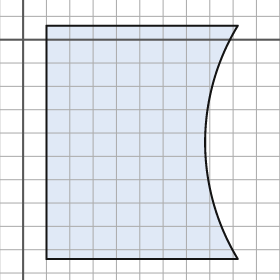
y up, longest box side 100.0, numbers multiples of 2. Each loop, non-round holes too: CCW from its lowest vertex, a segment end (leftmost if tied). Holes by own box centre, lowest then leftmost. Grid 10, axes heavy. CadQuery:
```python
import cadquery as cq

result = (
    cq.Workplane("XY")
    .moveTo(10.0, -94.0)
    .lineTo(92.0, -94.0)
    .threePointArc((78.0, -44.0), (92.0, 6.0))
    .lineTo(10.0, 6.0)
    .close()
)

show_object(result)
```